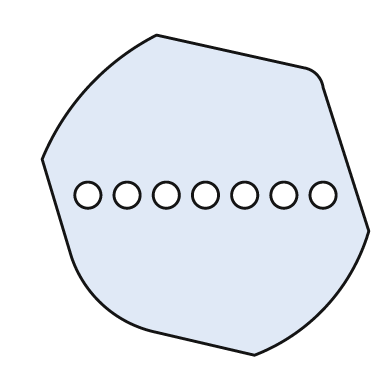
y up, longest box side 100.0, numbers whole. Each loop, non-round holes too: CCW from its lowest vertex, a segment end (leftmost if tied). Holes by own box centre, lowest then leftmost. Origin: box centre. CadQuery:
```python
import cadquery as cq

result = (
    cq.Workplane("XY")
    .moveTo(15.0, -49.0)
    .threePointArc((37.0, -34.0), (50.0, -11.0))
    .lineTo(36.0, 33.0)
    .threePointArc((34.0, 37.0), (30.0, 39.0))
    .lineTo(-15.0, 49.0)
    .threePointArc((-36.0, 33.0), (-50.0, 11.0))
    .lineTo(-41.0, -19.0)
    .threePointArc((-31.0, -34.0), (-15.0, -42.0))
    .close()
    .moveTo(-36.0, 0.0)
    .circle(4.0)
    .moveTo(-24.0, 0.0)
    .circle(4.0)
    .moveTo(-12.0, 0.0)
    .circle(4.0)
    .moveTo(0.0, 0.0)
    .circle(4.0)
    .moveTo(12.0, 0.0)
    .circle(4.0)
    .moveTo(24.0, 0.0)
    .circle(4.0)
    .moveTo(36.0, 0.0)
    .circle(4.0)
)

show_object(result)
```